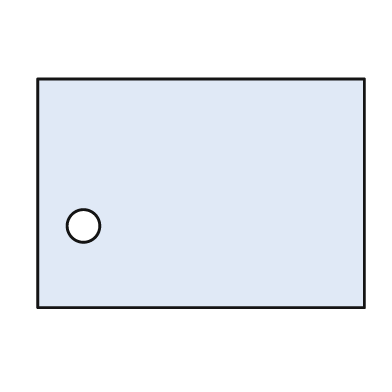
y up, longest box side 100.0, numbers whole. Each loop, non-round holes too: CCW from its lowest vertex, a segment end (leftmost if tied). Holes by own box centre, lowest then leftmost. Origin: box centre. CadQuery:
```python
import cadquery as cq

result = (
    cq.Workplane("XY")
    .moveTo(-50.0, -35.0)
    .lineTo(50.0, -35.0)
    .lineTo(50.0, 35.0)
    .lineTo(-50.0, 35.0)
    .close()
    .moveTo(-36.0, -10.0)
    .circle(5.0)
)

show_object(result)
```